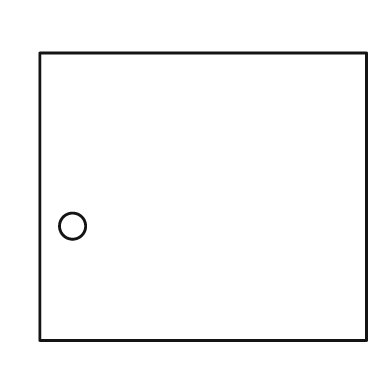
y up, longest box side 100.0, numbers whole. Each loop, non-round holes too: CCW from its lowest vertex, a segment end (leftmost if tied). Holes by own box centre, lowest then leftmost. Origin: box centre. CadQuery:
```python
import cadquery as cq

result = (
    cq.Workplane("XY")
    .moveTo(-50.0, -44.0)
    .lineTo(50.0, -44.0)
    .lineTo(50.0, 44.0)
    .lineTo(-50.0, 44.0)
    .close()
    .moveTo(-40.0, -9.0)
    .circle(4.0)
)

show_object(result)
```